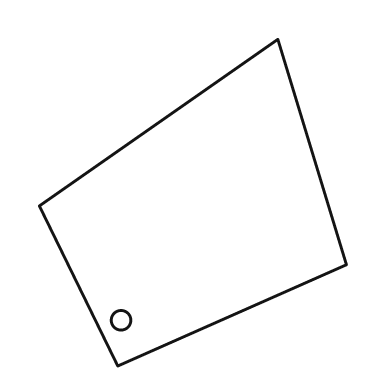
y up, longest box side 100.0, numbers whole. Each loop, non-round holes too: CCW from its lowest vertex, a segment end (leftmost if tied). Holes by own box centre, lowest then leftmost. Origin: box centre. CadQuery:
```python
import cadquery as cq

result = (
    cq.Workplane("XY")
    .moveTo(-23.0, -50.0)
    .lineTo(47.0, -19.0)
    .lineTo(26.0, 50.0)
    .lineTo(-47.0, -1.0)
    .close()
    .moveTo(-22.0, -36.0)
    .circle(3.0)
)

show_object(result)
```